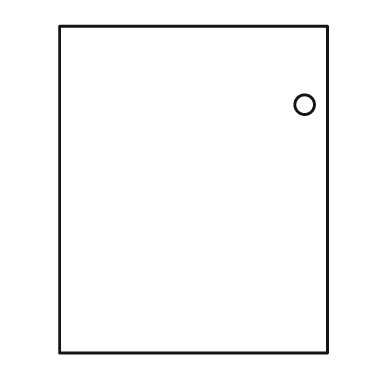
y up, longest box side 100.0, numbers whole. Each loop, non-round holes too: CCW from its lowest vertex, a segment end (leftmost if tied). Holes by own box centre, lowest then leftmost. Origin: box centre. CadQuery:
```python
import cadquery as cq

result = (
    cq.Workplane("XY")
    .moveTo(-41.0, -50.0)
    .lineTo(41.0, -50.0)
    .lineTo(41.0, 50.0)
    .lineTo(-41.0, 50.0)
    .close()
    .moveTo(34.0, 26.0)
    .circle(3.0)
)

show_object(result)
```